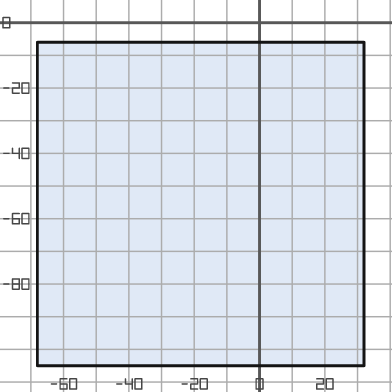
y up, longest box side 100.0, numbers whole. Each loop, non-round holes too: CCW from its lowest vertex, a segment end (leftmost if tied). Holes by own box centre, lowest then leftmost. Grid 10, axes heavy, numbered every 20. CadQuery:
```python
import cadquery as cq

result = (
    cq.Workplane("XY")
    .moveTo(-68.0, -105.0)
    .lineTo(32.0, -105.0)
    .lineTo(32.0, -6.0)
    .lineTo(-68.0, -6.0)
    .close()
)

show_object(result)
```